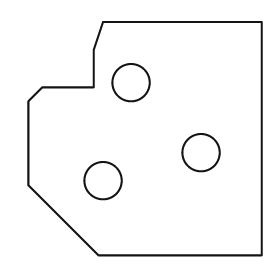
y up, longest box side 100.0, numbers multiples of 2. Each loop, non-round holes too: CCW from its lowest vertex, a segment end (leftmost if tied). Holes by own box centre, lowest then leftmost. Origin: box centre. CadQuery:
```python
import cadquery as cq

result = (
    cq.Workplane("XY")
    .moveTo(-20.0, -50.0)
    .lineTo(50.0, -50.0)
    .lineTo(50.0, 50.0)
    .lineTo(-18.0, 50.0)
    .lineTo(-22.0, 38.0)
    .lineTo(-22.0, 22.0)
    .lineTo(-44.0, 22.0)
    .lineTo(-50.0, 16.0)
    .lineTo(-50.0, -20.0)
    .close()
    .moveTo(-18.0, -18.0)
    .circle(8.0)
    .moveTo(24.0, -6.0)
    .circle(8.0)
    .moveTo(-6.0, 24.0)
    .circle(8.0)
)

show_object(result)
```